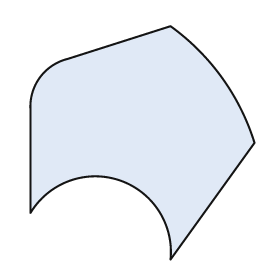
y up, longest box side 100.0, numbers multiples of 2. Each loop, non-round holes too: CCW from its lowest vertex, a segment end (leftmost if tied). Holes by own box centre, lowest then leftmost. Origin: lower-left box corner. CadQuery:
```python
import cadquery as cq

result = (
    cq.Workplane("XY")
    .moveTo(60.0, 0.0)
    .lineTo(96.0, 50.0)
    .threePointArc((82.0, 78.0), (60.0, 100.0))
    .lineTo(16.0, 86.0)
    .threePointArc((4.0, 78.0), (0.0, 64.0))
    .lineTo(0.0, 20.0)
    .threePointArc((38.0, 34.0), (60.0, 0.0))
    .close()
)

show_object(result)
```